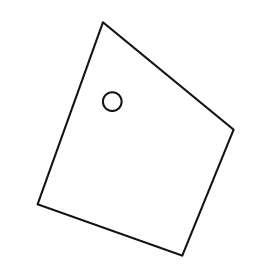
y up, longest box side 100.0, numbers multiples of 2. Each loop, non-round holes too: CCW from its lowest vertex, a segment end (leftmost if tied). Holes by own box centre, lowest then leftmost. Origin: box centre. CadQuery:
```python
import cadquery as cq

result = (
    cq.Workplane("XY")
    .moveTo(20.0, -50.0)
    .lineTo(42.0, 4.0)
    .lineTo(-14.0, 50.0)
    .lineTo(-42.0, -28.0)
    .close()
    .moveTo(-10.0, 16.0)
    .circle(4.0)
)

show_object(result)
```